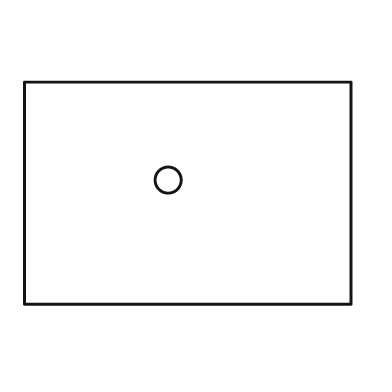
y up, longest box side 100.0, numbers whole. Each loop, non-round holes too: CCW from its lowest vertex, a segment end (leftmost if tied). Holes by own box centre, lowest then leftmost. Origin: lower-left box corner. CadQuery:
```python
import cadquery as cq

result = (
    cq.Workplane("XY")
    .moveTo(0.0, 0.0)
    .lineTo(100.0, 0.0)
    .lineTo(100.0, 68.0)
    .lineTo(0.0, 68.0)
    .close()
    .moveTo(44.0, 38.0)
    .circle(4.0)
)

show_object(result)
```